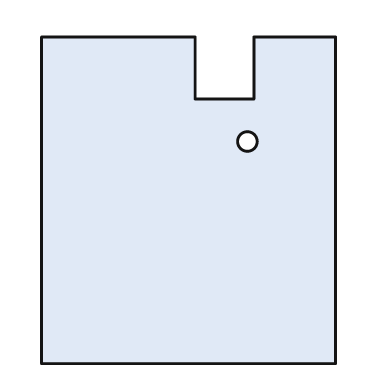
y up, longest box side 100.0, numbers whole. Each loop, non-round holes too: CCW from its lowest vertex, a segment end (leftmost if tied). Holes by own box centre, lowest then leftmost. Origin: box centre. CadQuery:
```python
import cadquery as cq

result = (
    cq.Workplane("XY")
    .moveTo(-45.0, -50.0)
    .lineTo(45.0, -50.0)
    .lineTo(45.0, 50.0)
    .lineTo(20.0, 50.0)
    .lineTo(20.0, 31.0)
    .lineTo(2.0, 31.0)
    .lineTo(2.0, 50.0)
    .lineTo(-45.0, 50.0)
    .close()
    .moveTo(18.0, 18.0)
    .circle(3.0)
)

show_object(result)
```